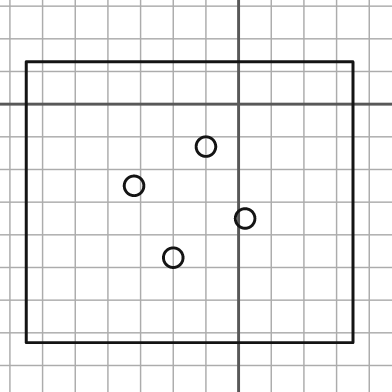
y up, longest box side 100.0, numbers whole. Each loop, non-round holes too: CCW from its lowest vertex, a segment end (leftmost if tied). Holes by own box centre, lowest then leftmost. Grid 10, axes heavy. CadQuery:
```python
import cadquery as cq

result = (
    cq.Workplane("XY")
    .moveTo(-65.0, -73.0)
    .lineTo(35.0, -73.0)
    .lineTo(35.0, 13.0)
    .lineTo(-65.0, 13.0)
    .close()
    .moveTo(-20.0, -47.0)
    .circle(3.0)
    .moveTo(2.0, -35.0)
    .circle(3.0)
    .moveTo(-32.0, -25.0)
    .circle(3.0)
    .moveTo(-10.0, -13.0)
    .circle(3.0)
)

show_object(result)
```